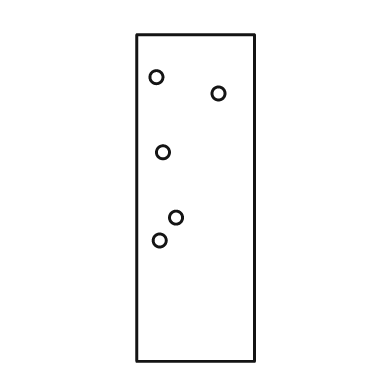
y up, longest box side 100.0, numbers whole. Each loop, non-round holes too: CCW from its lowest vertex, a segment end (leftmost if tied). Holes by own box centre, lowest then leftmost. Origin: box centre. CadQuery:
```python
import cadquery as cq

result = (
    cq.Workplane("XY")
    .moveTo(-18.0, -50.0)
    .lineTo(18.0, -50.0)
    .lineTo(18.0, 50.0)
    .lineTo(-18.0, 50.0)
    .close()
    .moveTo(-11.0, -13.0)
    .circle(2.0)
    .moveTo(-6.0, -6.0)
    .circle(2.0)
    .moveTo(-10.0, 14.0)
    .circle(2.0)
    .moveTo(7.0, 32.0)
    .circle(2.0)
    .moveTo(-12.0, 37.0)
    .circle(2.0)
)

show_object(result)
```